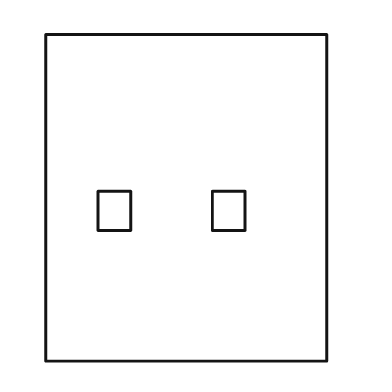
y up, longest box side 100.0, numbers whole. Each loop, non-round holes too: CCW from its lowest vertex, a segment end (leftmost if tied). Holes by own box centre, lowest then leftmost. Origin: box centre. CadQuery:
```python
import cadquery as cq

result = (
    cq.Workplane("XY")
    .moveTo(-43.0, -50.0)
    .lineTo(43.0, -50.0)
    .lineTo(43.0, 50.0)
    .lineTo(-43.0, 50.0)
    .close()
    .moveTo(-27.0, -10.0)
    .lineTo(-17.0, -10.0)
    .lineTo(-17.0, 2.0)
    .lineTo(-27.0, 2.0)
    .close()
    .moveTo(8.0, -10.0)
    .lineTo(18.0, -10.0)
    .lineTo(18.0, 2.0)
    .lineTo(8.0, 2.0)
    .close()
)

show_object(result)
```